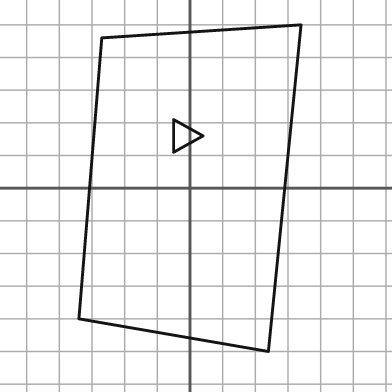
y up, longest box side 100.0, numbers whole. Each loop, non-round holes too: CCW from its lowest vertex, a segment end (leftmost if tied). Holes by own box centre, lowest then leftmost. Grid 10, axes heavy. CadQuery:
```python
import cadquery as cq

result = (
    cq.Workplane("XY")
    .moveTo(24.0, -50.0)
    .lineTo(34.0, 50.0)
    .lineTo(-27.0, 46.0)
    .lineTo(-34.0, -40.0)
    .close()
    .moveTo(-5.0, 11.0)
    .lineTo(4.0, 16.0)
    .lineTo(-5.0, 21.0)
    .close()
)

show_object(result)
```